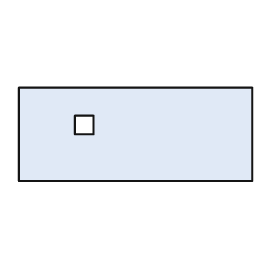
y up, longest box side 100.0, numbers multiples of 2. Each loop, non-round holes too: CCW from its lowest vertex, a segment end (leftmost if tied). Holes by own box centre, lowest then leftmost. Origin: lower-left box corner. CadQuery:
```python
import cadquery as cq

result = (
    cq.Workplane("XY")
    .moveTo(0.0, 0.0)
    .lineTo(100.0, 0.0)
    .lineTo(100.0, 40.0)
    .lineTo(0.0, 40.0)
    .close()
    .moveTo(24.0, 20.0)
    .lineTo(32.0, 20.0)
    .lineTo(32.0, 28.0)
    .lineTo(24.0, 28.0)
    .close()
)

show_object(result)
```